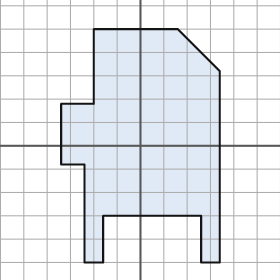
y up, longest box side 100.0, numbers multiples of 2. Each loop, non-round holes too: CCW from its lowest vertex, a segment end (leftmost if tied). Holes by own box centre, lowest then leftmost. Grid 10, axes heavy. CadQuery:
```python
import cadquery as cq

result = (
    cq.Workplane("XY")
    .moveTo(-24.0, -50.0)
    .lineTo(-16.0, -50.0)
    .lineTo(-16.0, -30.0)
    .lineTo(26.0, -30.0)
    .lineTo(26.0, -50.0)
    .lineTo(34.0, -50.0)
    .lineTo(34.0, 32.0)
    .lineTo(16.0, 50.0)
    .lineTo(-20.0, 50.0)
    .lineTo(-20.0, 18.0)
    .lineTo(-34.0, 18.0)
    .lineTo(-34.0, -8.0)
    .lineTo(-24.0, -8.0)
    .close()
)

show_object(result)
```